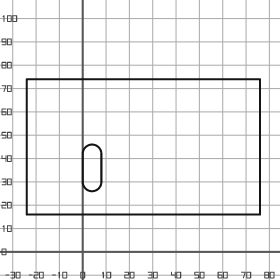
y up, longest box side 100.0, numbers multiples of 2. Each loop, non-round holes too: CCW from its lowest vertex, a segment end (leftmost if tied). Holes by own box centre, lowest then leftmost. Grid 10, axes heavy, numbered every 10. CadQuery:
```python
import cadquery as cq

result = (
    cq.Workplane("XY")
    .moveTo(-24.0, 16.0)
    .lineTo(76.0, 16.0)
    .lineTo(76.0, 74.0)
    .lineTo(-24.0, 74.0)
    .close()
    .moveTo(0.0, 30.0)
    .threePointArc((4.0, 26.0), (8.0, 30.0))
    .lineTo(8.0, 42.0)
    .threePointArc((4.0, 46.0), (0.0, 42.0))
    .close()
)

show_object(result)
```